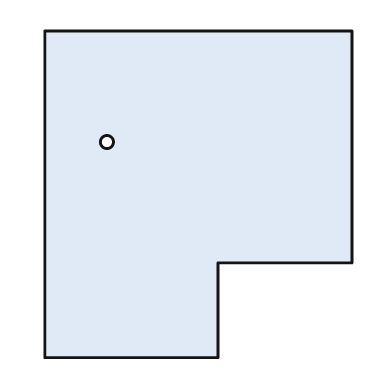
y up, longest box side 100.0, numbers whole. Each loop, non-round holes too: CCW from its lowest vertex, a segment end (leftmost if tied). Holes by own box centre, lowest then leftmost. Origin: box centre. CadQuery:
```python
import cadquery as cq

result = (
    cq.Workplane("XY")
    .moveTo(-47.0, -50.0)
    .lineTo(6.0, -50.0)
    .lineTo(6.0, -21.0)
    .lineTo(47.0, -21.0)
    .lineTo(47.0, 50.0)
    .lineTo(-47.0, 50.0)
    .close()
    .moveTo(-28.0, 16.0)
    .circle(2.0)
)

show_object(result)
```